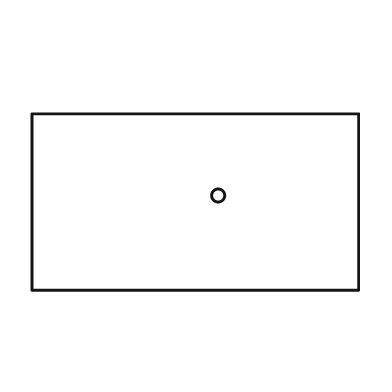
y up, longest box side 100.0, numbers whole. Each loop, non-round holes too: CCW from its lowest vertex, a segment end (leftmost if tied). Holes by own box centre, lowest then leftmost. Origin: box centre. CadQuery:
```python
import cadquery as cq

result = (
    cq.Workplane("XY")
    .moveTo(-50.0, -27.0)
    .lineTo(50.0, -27.0)
    .lineTo(50.0, 27.0)
    .lineTo(-50.0, 27.0)
    .close()
    .moveTo(7.0, 2.0)
    .circle(2.0)
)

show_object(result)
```